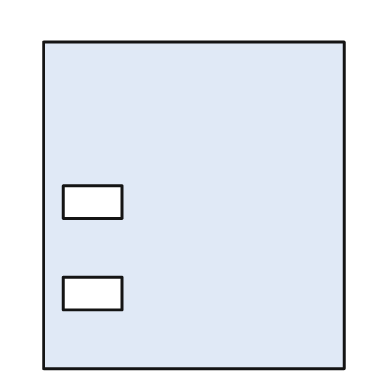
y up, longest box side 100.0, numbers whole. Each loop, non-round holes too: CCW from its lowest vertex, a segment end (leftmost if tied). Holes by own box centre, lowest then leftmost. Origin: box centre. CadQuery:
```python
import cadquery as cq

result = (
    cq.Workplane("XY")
    .moveTo(-46.0, -50.0)
    .lineTo(46.0, -50.0)
    .lineTo(46.0, 50.0)
    .lineTo(-46.0, 50.0)
    .close()
    .moveTo(-40.0, -32.0)
    .lineTo(-22.0, -32.0)
    .lineTo(-22.0, -22.0)
    .lineTo(-40.0, -22.0)
    .close()
    .moveTo(-40.0, -4.0)
    .lineTo(-22.0, -4.0)
    .lineTo(-22.0, 6.0)
    .lineTo(-40.0, 6.0)
    .close()
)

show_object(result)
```